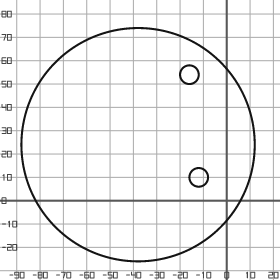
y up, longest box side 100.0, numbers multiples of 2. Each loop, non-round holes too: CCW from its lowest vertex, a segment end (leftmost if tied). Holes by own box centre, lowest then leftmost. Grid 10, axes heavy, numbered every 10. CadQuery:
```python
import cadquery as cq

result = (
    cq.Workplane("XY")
    .moveTo(-38.0, 24.0)
    .circle(50.0)
    .moveTo(-12.0, 10.0)
    .circle(4.0)
    .moveTo(-16.0, 54.0)
    .circle(4.0)
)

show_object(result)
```